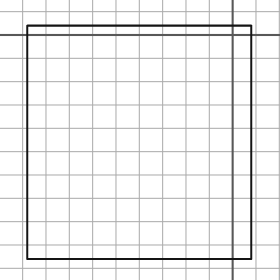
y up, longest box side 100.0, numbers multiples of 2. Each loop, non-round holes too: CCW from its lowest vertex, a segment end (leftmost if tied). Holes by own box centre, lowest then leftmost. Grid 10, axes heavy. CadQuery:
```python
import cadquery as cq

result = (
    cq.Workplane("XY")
    .moveTo(-88.0, -96.0)
    .lineTo(8.0, -96.0)
    .lineTo(8.0, 4.0)
    .lineTo(-88.0, 4.0)
    .close()
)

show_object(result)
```